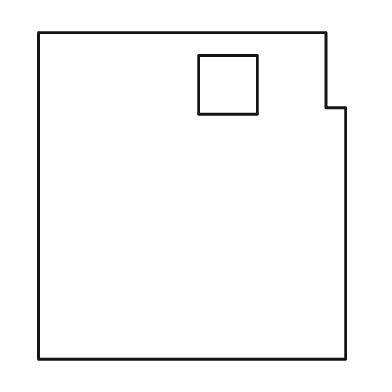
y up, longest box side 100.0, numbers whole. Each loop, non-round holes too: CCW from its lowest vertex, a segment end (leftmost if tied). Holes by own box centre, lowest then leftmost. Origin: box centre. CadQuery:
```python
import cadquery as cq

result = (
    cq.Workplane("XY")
    .moveTo(-47.0, -50.0)
    .lineTo(47.0, -50.0)
    .lineTo(47.0, 27.0)
    .lineTo(41.0, 27.0)
    .lineTo(41.0, 50.0)
    .lineTo(-47.0, 50.0)
    .close()
    .moveTo(2.0, 25.0)
    .lineTo(20.0, 25.0)
    .lineTo(20.0, 43.0)
    .lineTo(2.0, 43.0)
    .close()
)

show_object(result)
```